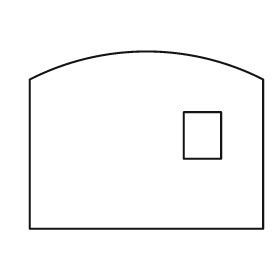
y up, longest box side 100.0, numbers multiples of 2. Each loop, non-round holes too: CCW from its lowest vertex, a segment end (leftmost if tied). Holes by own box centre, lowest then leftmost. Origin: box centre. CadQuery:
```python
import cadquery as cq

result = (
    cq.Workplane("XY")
    .moveTo(-50.0, -38.0)
    .lineTo(50.0, -38.0)
    .lineTo(50.0, 26.0)
    .threePointArc((0.0, 38.0), (-50.0, 26.0))
    .close()
    .moveTo(16.0, -8.0)
    .lineTo(32.0, -8.0)
    .lineTo(32.0, 12.0)
    .lineTo(16.0, 12.0)
    .close()
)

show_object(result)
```